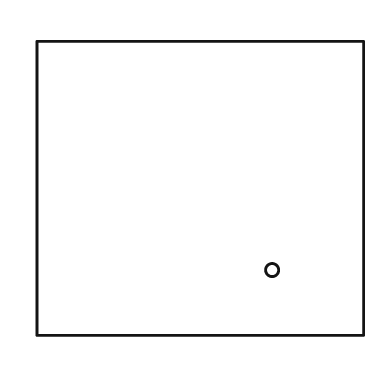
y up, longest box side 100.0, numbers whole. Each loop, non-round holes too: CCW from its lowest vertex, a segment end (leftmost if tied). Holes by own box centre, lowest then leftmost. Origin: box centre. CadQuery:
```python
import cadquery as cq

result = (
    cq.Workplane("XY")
    .moveTo(-50.0, -45.0)
    .lineTo(50.0, -45.0)
    .lineTo(50.0, 45.0)
    .lineTo(-50.0, 45.0)
    .close()
    .moveTo(22.0, -25.0)
    .circle(2.0)
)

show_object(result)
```